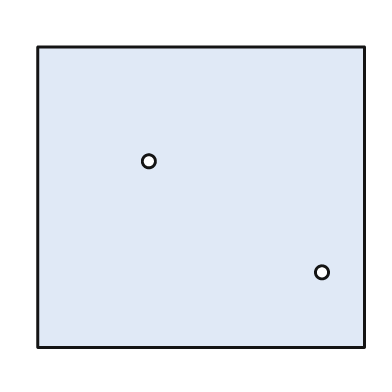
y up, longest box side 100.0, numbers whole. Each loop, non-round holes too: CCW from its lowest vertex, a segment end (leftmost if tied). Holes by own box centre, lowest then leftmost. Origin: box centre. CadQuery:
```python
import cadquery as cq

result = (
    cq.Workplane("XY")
    .moveTo(-50.0, -46.0)
    .lineTo(50.0, -46.0)
    .lineTo(50.0, 46.0)
    .lineTo(-50.0, 46.0)
    .close()
    .moveTo(37.0, -23.0)
    .circle(2.0)
    .moveTo(-16.0, 11.0)
    .circle(2.0)
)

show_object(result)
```